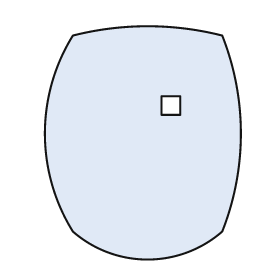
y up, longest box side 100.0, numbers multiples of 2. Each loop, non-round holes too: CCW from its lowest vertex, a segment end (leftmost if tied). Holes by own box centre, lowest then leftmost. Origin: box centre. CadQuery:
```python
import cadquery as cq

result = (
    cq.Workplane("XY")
    .moveTo(-30.0, -38.0)
    .threePointArc((2.0, -50.0), (34.0, -38.0))
    .threePointArc((42.0, 4.0), (34.0, 46.0))
    .threePointArc((2.0, 50.0), (-30.0, 46.0))
    .threePointArc((-42.0, 4.0), (-30.0, -38.0))
    .close()
    .moveTo(8.0, 12.0)
    .lineTo(16.0, 12.0)
    .lineTo(16.0, 20.0)
    .lineTo(8.0, 20.0)
    .close()
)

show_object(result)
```